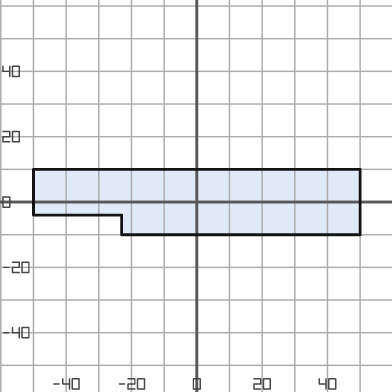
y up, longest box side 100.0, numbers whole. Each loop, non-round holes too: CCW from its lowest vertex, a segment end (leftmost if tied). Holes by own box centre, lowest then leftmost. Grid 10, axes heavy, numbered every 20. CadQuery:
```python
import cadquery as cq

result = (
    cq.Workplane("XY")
    .moveTo(-23.0, -10.0)
    .lineTo(50.0, -10.0)
    .lineTo(50.0, 10.0)
    .lineTo(-50.0, 10.0)
    .lineTo(-50.0, -4.0)
    .lineTo(-23.0, -4.0)
    .close()
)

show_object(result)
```